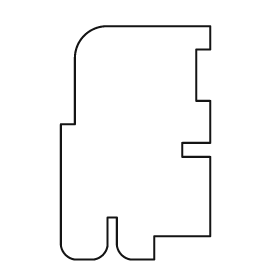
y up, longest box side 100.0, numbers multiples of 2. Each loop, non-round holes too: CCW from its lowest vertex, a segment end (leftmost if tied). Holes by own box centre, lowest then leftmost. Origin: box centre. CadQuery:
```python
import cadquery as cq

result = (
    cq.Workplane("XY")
    .moveTo(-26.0, -50.0)
    .lineTo(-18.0, -50.0)
    .threePointArc((-14.0, -48.0), (-12.0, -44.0))
    .lineTo(-12.0, -32.0)
    .lineTo(-8.0, -32.0)
    .lineTo(-8.0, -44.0)
    .threePointArc((-6.0, -48.0), (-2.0, -50.0))
    .lineTo(8.0, -50.0)
    .lineTo(8.0, -40.0)
    .lineTo(32.0, -40.0)
    .lineTo(32.0, -6.0)
    .lineTo(20.0, -6.0)
    .lineTo(20.0, 0.0)
    .lineTo(32.0, 0.0)
    .lineTo(32.0, 18.0)
    .lineTo(26.0, 18.0)
    .lineTo(26.0, 40.0)
    .lineTo(32.0, 40.0)
    .lineTo(32.0, 50.0)
    .lineTo(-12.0, 50.0)
    .threePointArc((-22.0, 46.0), (-26.0, 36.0))
    .lineTo(-26.0, 8.0)
    .lineTo(-32.0, 8.0)
    .lineTo(-32.0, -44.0)
    .threePointArc((-30.0, -48.0), (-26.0, -50.0))
    .close()
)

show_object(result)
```